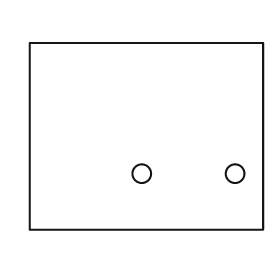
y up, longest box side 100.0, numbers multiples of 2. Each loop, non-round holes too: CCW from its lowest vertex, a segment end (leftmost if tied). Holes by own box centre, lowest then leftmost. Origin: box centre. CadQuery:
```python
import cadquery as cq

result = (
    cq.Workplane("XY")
    .moveTo(-50.0, -40.0)
    .lineTo(50.0, -40.0)
    .lineTo(50.0, 40.0)
    .lineTo(-50.0, 40.0)
    .close()
    .moveTo(-2.0, -16.0)
    .circle(4.0)
    .moveTo(38.0, -16.0)
    .circle(4.0)
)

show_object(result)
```